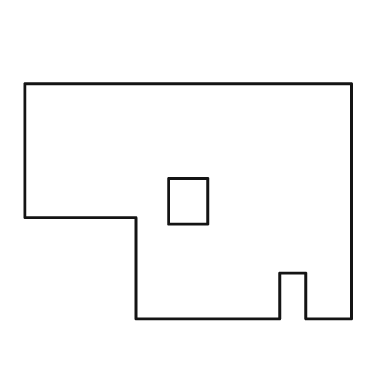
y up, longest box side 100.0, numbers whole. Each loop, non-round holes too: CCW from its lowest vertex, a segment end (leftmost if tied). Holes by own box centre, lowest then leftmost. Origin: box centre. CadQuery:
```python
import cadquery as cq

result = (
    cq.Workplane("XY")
    .moveTo(-16.0, -36.0)
    .lineTo(28.0, -36.0)
    .lineTo(28.0, -22.0)
    .lineTo(36.0, -22.0)
    .lineTo(36.0, -36.0)
    .lineTo(50.0, -36.0)
    .lineTo(50.0, 36.0)
    .lineTo(-50.0, 36.0)
    .lineTo(-50.0, -5.0)
    .lineTo(-16.0, -5.0)
    .close()
    .moveTo(-6.0, -7.0)
    .lineTo(6.0, -7.0)
    .lineTo(6.0, 7.0)
    .lineTo(-6.0, 7.0)
    .close()
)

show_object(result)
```